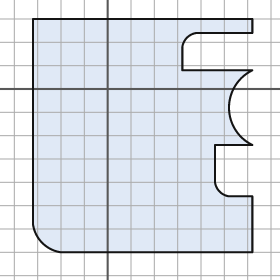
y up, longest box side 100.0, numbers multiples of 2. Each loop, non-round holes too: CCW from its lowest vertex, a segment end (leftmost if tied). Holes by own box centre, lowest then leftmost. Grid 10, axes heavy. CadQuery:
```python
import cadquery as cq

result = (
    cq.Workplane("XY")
    .moveTo(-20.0, -70.0)
    .lineTo(62.0, -70.0)
    .lineTo(62.0, -46.0)
    .lineTo(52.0, -46.0)
    .threePointArc((48.0, -44.0), (46.0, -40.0))
    .lineTo(46.0, -24.0)
    .lineTo(62.0, -24.0)
    .threePointArc((52.0, -8.0), (62.0, 8.0))
    .lineTo(32.0, 8.0)
    .lineTo(32.0, 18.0)
    .threePointArc((34.0, 22.0), (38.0, 24.0))
    .lineTo(62.0, 24.0)
    .lineTo(62.0, 30.0)
    .lineTo(-32.0, 30.0)
    .lineTo(-32.0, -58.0)
    .threePointArc((-28.0, -66.0), (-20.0, -70.0))
    .close()
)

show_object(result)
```